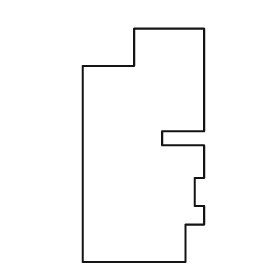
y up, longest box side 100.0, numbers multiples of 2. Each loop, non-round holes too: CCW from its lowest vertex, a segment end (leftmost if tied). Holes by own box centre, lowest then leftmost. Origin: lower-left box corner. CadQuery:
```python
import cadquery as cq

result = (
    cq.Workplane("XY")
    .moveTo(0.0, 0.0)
    .lineTo(44.0, 0.0)
    .lineTo(44.0, 16.0)
    .lineTo(52.0, 16.0)
    .lineTo(52.0, 24.0)
    .lineTo(48.0, 24.0)
    .lineTo(48.0, 36.0)
    .lineTo(52.0, 36.0)
    .lineTo(52.0, 50.0)
    .lineTo(34.0, 50.0)
    .lineTo(34.0, 56.0)
    .lineTo(52.0, 56.0)
    .lineTo(52.0, 100.0)
    .lineTo(22.0, 100.0)
    .lineTo(22.0, 84.0)
    .lineTo(0.0, 84.0)
    .close()
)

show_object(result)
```